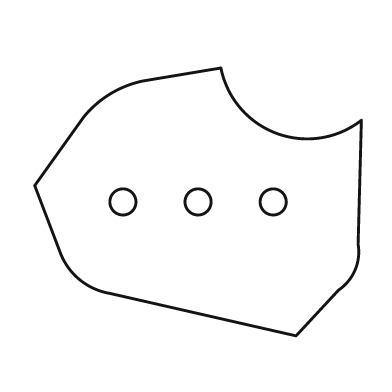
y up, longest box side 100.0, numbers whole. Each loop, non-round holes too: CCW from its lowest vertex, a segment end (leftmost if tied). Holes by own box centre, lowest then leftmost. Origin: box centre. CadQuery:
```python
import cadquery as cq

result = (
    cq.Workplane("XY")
    .moveTo(30.0, -41.0)
    .lineTo(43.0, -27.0)
    .threePointArc((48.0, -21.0), (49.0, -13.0))
    .lineTo(50.0, 25.0)
    .threePointArc((24.0, 21.0), (7.0, 41.0))
    .lineTo(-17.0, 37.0)
    .threePointArc((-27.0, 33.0), (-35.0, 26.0))
    .lineTo(-50.0, 5.0)
    .lineTo(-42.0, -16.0)
    .threePointArc((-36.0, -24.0), (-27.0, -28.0))
    .close()
    .moveTo(-23.0, 0.0)
    .circle(4.0)
    .moveTo(0.0, 0.0)
    .circle(4.0)
    .moveTo(23.0, 0.0)
    .circle(4.0)
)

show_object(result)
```